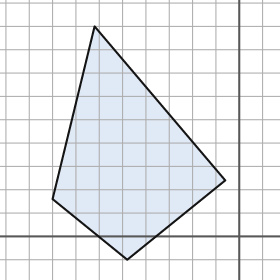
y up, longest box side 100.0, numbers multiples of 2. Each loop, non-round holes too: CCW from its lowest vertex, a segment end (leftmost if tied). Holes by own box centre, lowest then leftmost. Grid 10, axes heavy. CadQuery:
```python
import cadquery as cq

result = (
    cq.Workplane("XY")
    .moveTo(-48.0, -10.0)
    .lineTo(-6.0, 24.0)
    .lineTo(-62.0, 90.0)
    .lineTo(-80.0, 16.0)
    .close()
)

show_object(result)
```